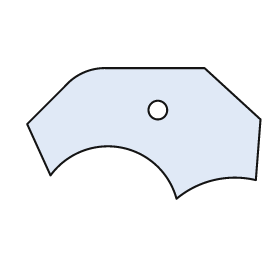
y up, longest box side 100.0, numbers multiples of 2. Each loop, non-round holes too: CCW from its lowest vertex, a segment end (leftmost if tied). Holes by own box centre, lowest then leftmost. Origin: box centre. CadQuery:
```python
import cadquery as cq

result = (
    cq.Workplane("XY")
    .moveTo(14.0, -28.0)
    .threePointArc((30.0, -20.0), (48.0, -20.0))
    .lineTo(50.0, 6.0)
    .lineTo(26.0, 28.0)
    .lineTo(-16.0, 28.0)
    .threePointArc((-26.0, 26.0), (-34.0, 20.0))
    .lineTo(-50.0, 4.0)
    .lineTo(-40.0, -18.0)
    .threePointArc((-10.0, -6.0), (14.0, -28.0))
    .close()
    .moveTo(6.0, 10.0)
    .circle(4.0)
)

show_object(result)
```